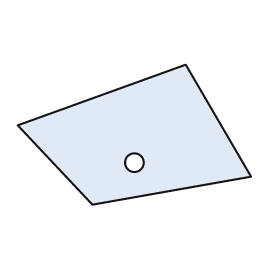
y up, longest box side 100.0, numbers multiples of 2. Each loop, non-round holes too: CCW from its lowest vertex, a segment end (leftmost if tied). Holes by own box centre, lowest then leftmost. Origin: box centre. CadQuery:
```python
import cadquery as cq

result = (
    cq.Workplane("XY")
    .moveTo(-18.0, -30.0)
    .lineTo(50.0, -18.0)
    .lineTo(22.0, 30.0)
    .lineTo(-50.0, 4.0)
    .close()
    .moveTo(0.0, -12.0)
    .circle(4.0)
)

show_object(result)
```